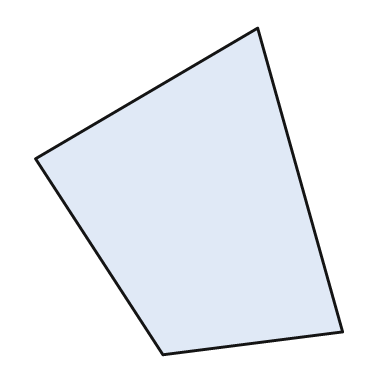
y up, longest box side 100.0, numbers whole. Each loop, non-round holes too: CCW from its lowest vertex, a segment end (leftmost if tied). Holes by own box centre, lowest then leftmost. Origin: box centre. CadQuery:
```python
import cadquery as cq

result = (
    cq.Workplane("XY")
    .moveTo(-8.0, -50.0)
    .lineTo(47.0, -43.0)
    .lineTo(21.0, 50.0)
    .lineTo(-47.0, 10.0)
    .close()
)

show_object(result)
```